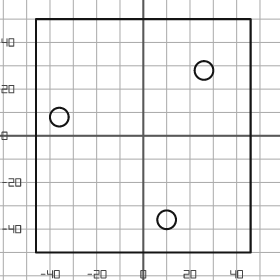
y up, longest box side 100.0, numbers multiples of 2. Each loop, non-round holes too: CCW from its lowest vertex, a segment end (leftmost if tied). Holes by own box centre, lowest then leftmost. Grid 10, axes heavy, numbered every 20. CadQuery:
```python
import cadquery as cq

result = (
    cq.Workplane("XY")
    .moveTo(-46.0, -50.0)
    .lineTo(46.0, -50.0)
    .lineTo(46.0, 50.0)
    .lineTo(-46.0, 50.0)
    .close()
    .moveTo(10.0, -36.0)
    .circle(4.0)
    .moveTo(-36.0, 8.0)
    .circle(4.0)
    .moveTo(26.0, 28.0)
    .circle(4.0)
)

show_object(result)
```